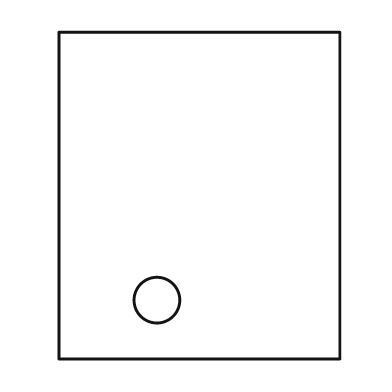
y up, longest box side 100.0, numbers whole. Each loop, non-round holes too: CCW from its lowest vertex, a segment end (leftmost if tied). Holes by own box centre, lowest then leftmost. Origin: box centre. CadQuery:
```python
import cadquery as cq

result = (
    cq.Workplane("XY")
    .moveTo(-43.0, -50.0)
    .lineTo(43.0, -50.0)
    .lineTo(43.0, 50.0)
    .lineTo(-43.0, 50.0)
    .close()
    .moveTo(-13.0, -32.0)
    .circle(7.0)
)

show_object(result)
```